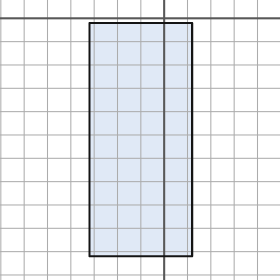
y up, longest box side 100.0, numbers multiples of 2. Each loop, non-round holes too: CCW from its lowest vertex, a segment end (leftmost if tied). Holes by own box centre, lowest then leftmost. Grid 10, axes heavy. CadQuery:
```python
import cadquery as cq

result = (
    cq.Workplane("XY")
    .moveTo(-32.0, -102.0)
    .lineTo(12.0, -102.0)
    .lineTo(12.0, -2.0)
    .lineTo(-32.0, -2.0)
    .close()
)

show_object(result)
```